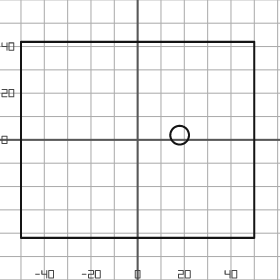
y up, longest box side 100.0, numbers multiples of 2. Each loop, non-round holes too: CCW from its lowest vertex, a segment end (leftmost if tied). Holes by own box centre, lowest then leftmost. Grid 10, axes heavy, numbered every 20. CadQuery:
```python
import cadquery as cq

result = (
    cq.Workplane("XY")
    .moveTo(-50.0, -42.0)
    .lineTo(50.0, -42.0)
    .lineTo(50.0, 42.0)
    .lineTo(-50.0, 42.0)
    .close()
    .moveTo(18.0, 2.0)
    .circle(4.0)
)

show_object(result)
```